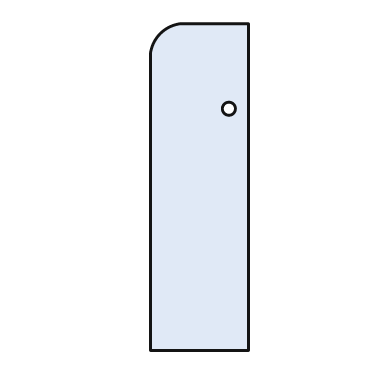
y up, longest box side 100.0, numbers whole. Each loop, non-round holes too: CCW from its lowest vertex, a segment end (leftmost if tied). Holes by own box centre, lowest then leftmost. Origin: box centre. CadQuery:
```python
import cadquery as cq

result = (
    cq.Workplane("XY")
    .moveTo(-15.0, -50.0)
    .lineTo(15.0, -50.0)
    .lineTo(15.0, 50.0)
    .lineTo(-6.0, 50.0)
    .threePointArc((-12.0, 47.0), (-15.0, 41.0))
    .close()
    .moveTo(9.0, 24.0)
    .circle(2.0)
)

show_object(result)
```